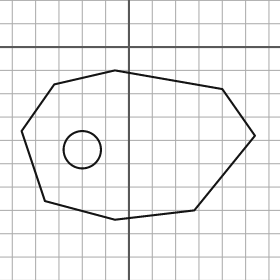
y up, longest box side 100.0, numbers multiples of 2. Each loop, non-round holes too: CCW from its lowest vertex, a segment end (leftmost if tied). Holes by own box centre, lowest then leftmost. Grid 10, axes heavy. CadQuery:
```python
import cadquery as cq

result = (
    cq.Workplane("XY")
    .moveTo(-6.0, -74.0)
    .lineTo(28.0, -70.0)
    .lineTo(54.0, -38.0)
    .lineTo(40.0, -18.0)
    .lineTo(-6.0, -10.0)
    .lineTo(-32.0, -16.0)
    .lineTo(-46.0, -36.0)
    .lineTo(-36.0, -66.0)
    .close()
    .moveTo(-20.0, -44.0)
    .circle(8.0)
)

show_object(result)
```